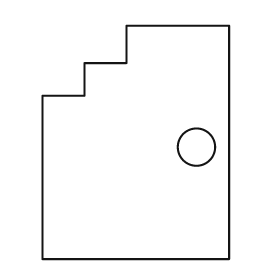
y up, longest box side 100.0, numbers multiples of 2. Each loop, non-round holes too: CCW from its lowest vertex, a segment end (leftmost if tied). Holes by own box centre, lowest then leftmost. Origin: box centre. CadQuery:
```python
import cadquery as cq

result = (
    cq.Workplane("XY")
    .moveTo(-40.0, -50.0)
    .lineTo(40.0, -50.0)
    .lineTo(40.0, 50.0)
    .lineTo(-4.0, 50.0)
    .lineTo(-4.0, 34.0)
    .lineTo(-22.0, 34.0)
    .lineTo(-22.0, 20.0)
    .lineTo(-40.0, 20.0)
    .close()
    .moveTo(26.0, -2.0)
    .circle(8.0)
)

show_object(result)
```